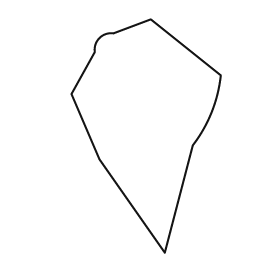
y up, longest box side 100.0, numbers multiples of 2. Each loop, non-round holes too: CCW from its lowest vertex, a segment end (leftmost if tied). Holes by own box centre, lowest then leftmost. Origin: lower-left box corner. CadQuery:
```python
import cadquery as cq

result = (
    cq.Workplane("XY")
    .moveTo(40.0, 0.0)
    .lineTo(52.0, 46.0)
    .threePointArc((60.0, 60.0), (64.0, 76.0))
    .lineTo(34.0, 100.0)
    .lineTo(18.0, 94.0)
    .threePointArc((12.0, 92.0), (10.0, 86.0))
    .lineTo(0.0, 68.0)
    .lineTo(12.0, 40.0)
    .close()
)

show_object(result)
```